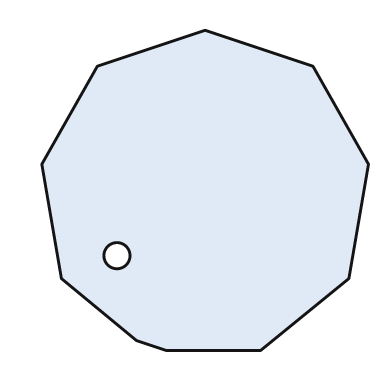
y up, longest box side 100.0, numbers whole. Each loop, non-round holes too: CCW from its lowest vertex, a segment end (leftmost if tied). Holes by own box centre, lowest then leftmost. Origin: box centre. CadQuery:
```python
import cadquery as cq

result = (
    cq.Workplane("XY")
    .moveTo(-12.0, -49.0)
    .lineTo(17.0, -49.0)
    .lineTo(44.0, -27.0)
    .lineTo(50.0, 8.0)
    .lineTo(33.0, 38.0)
    .lineTo(0.0, 49.0)
    .lineTo(-33.0, 38.0)
    .lineTo(-50.0, 8.0)
    .lineTo(-44.0, -27.0)
    .lineTo(-21.0, -46.0)
    .close()
    .moveTo(-27.0, -20.0)
    .circle(4.0)
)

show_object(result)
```